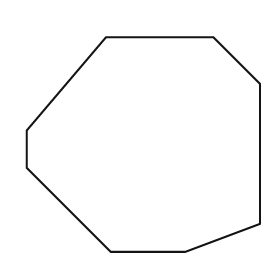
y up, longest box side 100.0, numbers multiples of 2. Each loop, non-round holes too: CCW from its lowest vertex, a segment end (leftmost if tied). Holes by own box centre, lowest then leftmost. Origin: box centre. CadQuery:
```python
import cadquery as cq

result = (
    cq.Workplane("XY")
    .moveTo(-14.0, -46.0)
    .lineTo(18.0, -46.0)
    .lineTo(50.0, -34.0)
    .lineTo(50.0, 26.0)
    .lineTo(30.0, 46.0)
    .lineTo(-16.0, 46.0)
    .lineTo(-50.0, 6.0)
    .lineTo(-50.0, -10.0)
    .close()
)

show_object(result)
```